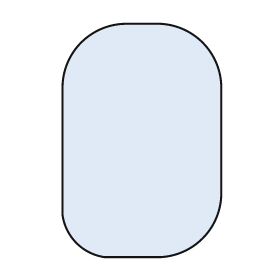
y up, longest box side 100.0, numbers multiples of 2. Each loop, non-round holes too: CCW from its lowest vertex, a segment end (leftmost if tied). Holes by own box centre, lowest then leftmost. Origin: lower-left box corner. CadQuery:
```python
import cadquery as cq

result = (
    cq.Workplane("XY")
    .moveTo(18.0, 0.0)
    .lineTo(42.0, 0.0)
    .threePointArc((60.0, 8.0), (68.0, 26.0))
    .lineTo(68.0, 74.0)
    .threePointArc((60.0, 92.0), (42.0, 100.0))
    .lineTo(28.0, 100.0)
    .threePointArc((8.0, 92.0), (0.0, 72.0))
    .lineTo(0.0, 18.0)
    .threePointArc((6.0, 6.0), (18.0, 0.0))
    .close()
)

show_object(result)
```